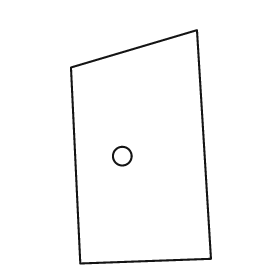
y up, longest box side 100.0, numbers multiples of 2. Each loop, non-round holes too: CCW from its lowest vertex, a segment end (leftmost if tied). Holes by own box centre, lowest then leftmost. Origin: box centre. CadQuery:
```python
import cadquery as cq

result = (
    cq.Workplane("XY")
    .moveTo(-26.0, -50.0)
    .lineTo(30.0, -48.0)
    .lineTo(24.0, 50.0)
    .lineTo(-30.0, 34.0)
    .close()
    .moveTo(-8.0, -4.0)
    .circle(4.0)
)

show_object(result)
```